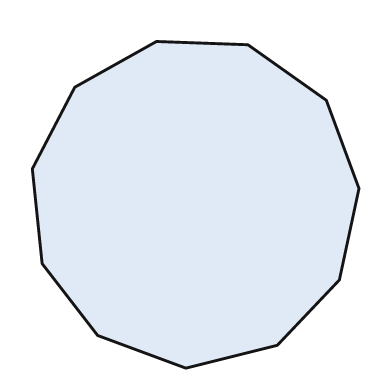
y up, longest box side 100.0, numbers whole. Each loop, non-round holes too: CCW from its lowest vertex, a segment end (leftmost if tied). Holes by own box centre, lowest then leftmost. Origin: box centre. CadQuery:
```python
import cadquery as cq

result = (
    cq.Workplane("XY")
    .moveTo(-3.0, -50.0)
    .lineTo(25.0, -43.0)
    .lineTo(44.0, -23.0)
    .lineTo(50.0, 5.0)
    .lineTo(40.0, 32.0)
    .lineTo(16.0, 49.0)
    .lineTo(-12.0, 50.0)
    .lineTo(-37.0, 36.0)
    .lineTo(-50.0, 11.0)
    .lineTo(-47.0, -18.0)
    .lineTo(-30.0, -40.0)
    .close()
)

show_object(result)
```